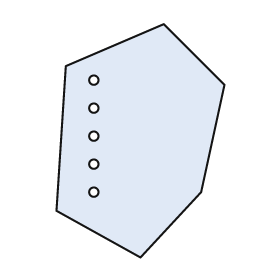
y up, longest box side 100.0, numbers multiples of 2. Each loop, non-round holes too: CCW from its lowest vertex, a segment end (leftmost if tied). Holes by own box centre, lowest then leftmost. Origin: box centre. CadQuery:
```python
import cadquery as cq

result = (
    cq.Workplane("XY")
    .moveTo(0.0, -50.0)
    .lineTo(26.0, -22.0)
    .lineTo(36.0, 24.0)
    .lineTo(10.0, 50.0)
    .lineTo(-32.0, 32.0)
    .lineTo(-36.0, -30.0)
    .close()
    .moveTo(-20.0, -22.0)
    .circle(2.0)
    .moveTo(-20.0, -10.0)
    .circle(2.0)
    .moveTo(-20.0, 2.0)
    .circle(2.0)
    .moveTo(-20.0, 14.0)
    .circle(2.0)
    .moveTo(-20.0, 26.0)
    .circle(2.0)
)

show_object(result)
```